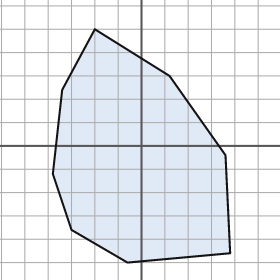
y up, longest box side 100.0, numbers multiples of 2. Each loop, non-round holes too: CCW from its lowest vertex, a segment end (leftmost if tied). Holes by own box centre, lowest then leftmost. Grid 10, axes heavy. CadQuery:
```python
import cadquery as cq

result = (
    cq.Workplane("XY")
    .moveTo(-6.0, -50.0)
    .lineTo(38.0, -46.0)
    .lineTo(36.0, -4.0)
    .lineTo(12.0, 30.0)
    .lineTo(-20.0, 50.0)
    .lineTo(-34.0, 24.0)
    .lineTo(-38.0, -12.0)
    .lineTo(-30.0, -36.0)
    .close()
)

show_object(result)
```